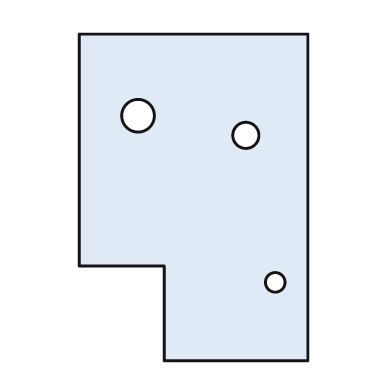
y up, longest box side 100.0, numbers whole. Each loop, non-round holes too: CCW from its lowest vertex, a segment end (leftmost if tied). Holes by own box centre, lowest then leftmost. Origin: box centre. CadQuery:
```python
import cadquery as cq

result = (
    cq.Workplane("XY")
    .moveTo(-9.0, -50.0)
    .lineTo(35.0, -50.0)
    .lineTo(35.0, 50.0)
    .lineTo(-35.0, 50.0)
    .lineTo(-35.0, -21.0)
    .lineTo(-9.0, -21.0)
    .close()
    .moveTo(25.0, -26.0)
    .circle(3.0)
    .moveTo(16.0, 19.0)
    .circle(4.0)
    .moveTo(-17.0, 25.0)
    .circle(5.0)
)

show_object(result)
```